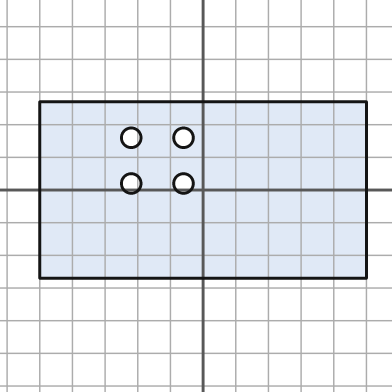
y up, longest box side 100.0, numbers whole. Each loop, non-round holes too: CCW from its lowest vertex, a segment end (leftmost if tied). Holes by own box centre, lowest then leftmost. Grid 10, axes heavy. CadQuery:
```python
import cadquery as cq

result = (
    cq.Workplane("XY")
    .moveTo(-50.0, -27.0)
    .lineTo(50.0, -27.0)
    .lineTo(50.0, 27.0)
    .lineTo(-50.0, 27.0)
    .close()
    .moveTo(-22.0, 2.0)
    .circle(3.0)
    .moveTo(-6.0, 2.0)
    .circle(3.0)
    .moveTo(-22.0, 16.0)
    .circle(3.0)
    .moveTo(-6.0, 16.0)
    .circle(3.0)
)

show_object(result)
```